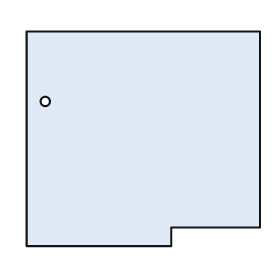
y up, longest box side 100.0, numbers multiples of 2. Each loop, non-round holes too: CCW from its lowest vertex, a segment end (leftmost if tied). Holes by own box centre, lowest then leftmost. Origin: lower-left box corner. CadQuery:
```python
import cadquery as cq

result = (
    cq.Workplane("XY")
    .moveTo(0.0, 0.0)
    .lineTo(62.0, 0.0)
    .lineTo(62.0, 8.0)
    .lineTo(100.0, 8.0)
    .lineTo(100.0, 92.0)
    .lineTo(0.0, 92.0)
    .close()
    .moveTo(8.0, 62.0)
    .circle(2.0)
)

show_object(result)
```